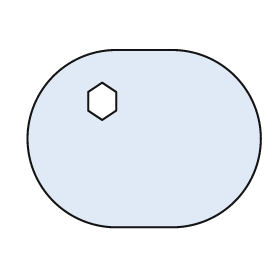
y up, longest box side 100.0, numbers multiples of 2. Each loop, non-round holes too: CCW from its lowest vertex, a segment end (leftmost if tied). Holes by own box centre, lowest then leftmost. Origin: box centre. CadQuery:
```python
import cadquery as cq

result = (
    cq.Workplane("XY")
    .moveTo(-12.0, -38.0)
    .lineTo(12.0, -38.0)
    .threePointArc((50.0, 0.0), (12.0, 38.0))
    .lineTo(-12.0, 38.0)
    .threePointArc((-50.0, 0.0), (-12.0, -38.0))
    .close()
    .moveTo(-18.0, 8.0)
    .lineTo(-12.0, 12.0)
    .lineTo(-12.0, 20.0)
    .lineTo(-18.0, 24.0)
    .lineTo(-24.0, 20.0)
    .lineTo(-24.0, 12.0)
    .close()
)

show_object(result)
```